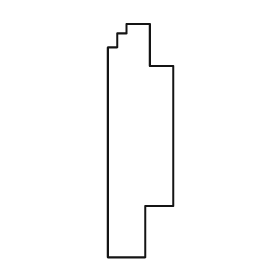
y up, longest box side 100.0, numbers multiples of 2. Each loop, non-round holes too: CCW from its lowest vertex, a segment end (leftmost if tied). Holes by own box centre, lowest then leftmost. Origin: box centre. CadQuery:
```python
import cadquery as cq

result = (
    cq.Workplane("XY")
    .moveTo(-14.0, -50.0)
    .lineTo(2.0, -50.0)
    .lineTo(2.0, -28.0)
    .lineTo(14.0, -28.0)
    .lineTo(14.0, 32.0)
    .lineTo(4.0, 32.0)
    .lineTo(4.0, 50.0)
    .lineTo(-6.0, 50.0)
    .lineTo(-6.0, 46.0)
    .lineTo(-10.0, 46.0)
    .lineTo(-10.0, 40.0)
    .lineTo(-14.0, 40.0)
    .close()
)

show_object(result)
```